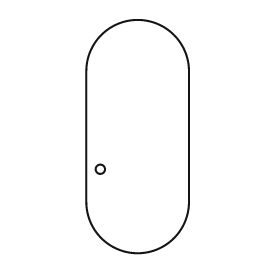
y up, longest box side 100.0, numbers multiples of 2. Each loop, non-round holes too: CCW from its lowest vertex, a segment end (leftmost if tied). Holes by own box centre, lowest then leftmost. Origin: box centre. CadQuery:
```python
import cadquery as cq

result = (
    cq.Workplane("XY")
    .moveTo(-22.0, -28.0)
    .threePointArc((0.0, -50.0), (22.0, -28.0))
    .lineTo(22.0, 28.0)
    .threePointArc((0.0, 50.0), (-22.0, 28.0))
    .close()
    .moveTo(-16.0, -14.0)
    .circle(2.0)
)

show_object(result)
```